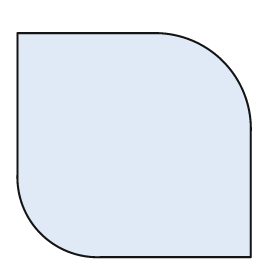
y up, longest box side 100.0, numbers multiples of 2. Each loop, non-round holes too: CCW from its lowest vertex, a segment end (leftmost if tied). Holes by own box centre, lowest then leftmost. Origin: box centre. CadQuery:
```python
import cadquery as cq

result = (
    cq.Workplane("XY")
    .moveTo(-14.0, -48.0)
    .lineTo(50.0, -48.0)
    .lineTo(50.0, 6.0)
    .threePointArc((38.0, 36.0), (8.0, 48.0))
    .lineTo(-50.0, 48.0)
    .lineTo(-50.0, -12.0)
    .threePointArc((-40.0, -38.0), (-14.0, -48.0))
    .close()
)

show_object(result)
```